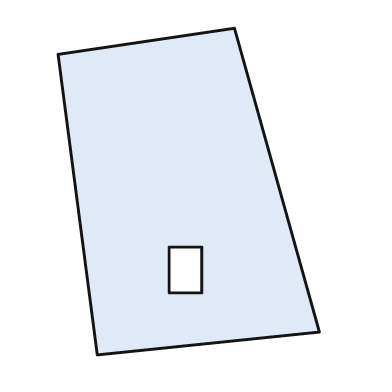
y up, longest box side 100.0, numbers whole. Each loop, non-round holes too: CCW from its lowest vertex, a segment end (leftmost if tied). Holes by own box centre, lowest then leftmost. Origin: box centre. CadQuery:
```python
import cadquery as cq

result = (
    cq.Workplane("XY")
    .moveTo(-28.0, -50.0)
    .lineTo(40.0, -43.0)
    .lineTo(14.0, 50.0)
    .lineTo(-40.0, 42.0)
    .close()
    .moveTo(-6.0, -31.0)
    .lineTo(4.0, -31.0)
    .lineTo(4.0, -17.0)
    .lineTo(-6.0, -17.0)
    .close()
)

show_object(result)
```